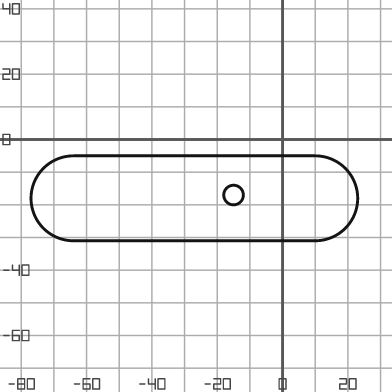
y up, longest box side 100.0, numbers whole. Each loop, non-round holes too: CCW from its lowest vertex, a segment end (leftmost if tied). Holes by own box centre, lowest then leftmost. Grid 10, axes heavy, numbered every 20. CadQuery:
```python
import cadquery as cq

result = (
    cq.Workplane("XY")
    .moveTo(-64.0, -31.0)
    .lineTo(10.0, -31.0)
    .threePointArc((23.0, -18.0), (10.0, -5.0))
    .lineTo(-64.0, -5.0)
    .threePointArc((-77.0, -18.0), (-64.0, -31.0))
    .close()
    .moveTo(-15.0, -17.0)
    .circle(3.0)
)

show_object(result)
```